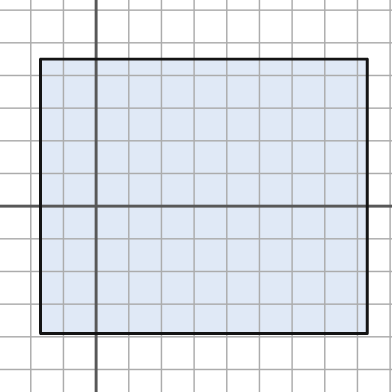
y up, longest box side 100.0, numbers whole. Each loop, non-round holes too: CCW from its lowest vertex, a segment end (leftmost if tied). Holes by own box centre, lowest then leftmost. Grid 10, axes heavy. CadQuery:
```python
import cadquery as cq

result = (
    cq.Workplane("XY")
    .moveTo(-17.0, -39.0)
    .lineTo(83.0, -39.0)
    .lineTo(83.0, 45.0)
    .lineTo(-17.0, 45.0)
    .close()
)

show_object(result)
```